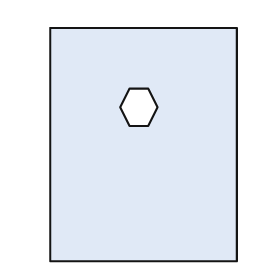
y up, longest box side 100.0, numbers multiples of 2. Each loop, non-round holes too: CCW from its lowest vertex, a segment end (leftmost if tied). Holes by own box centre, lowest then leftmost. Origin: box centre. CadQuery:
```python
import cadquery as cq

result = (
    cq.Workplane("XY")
    .moveTo(-40.0, -50.0)
    .lineTo(40.0, -50.0)
    .lineTo(40.0, 50.0)
    .lineTo(-40.0, 50.0)
    .close()
    .moveTo(-6.0, 8.0)
    .lineTo(2.0, 8.0)
    .lineTo(6.0, 16.0)
    .lineTo(2.0, 24.0)
    .lineTo(-6.0, 24.0)
    .lineTo(-10.0, 16.0)
    .close()
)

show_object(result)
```